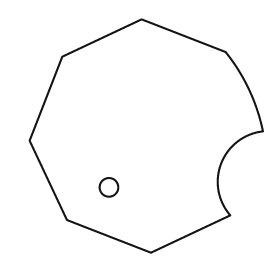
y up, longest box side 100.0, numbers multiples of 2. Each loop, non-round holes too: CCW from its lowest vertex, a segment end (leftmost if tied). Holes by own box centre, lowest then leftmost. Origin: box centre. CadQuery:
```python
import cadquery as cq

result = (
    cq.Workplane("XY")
    .moveTo(2.0, -50.0)
    .lineTo(36.0, -34.0)
    .threePointArc((32.0, -12.0), (50.0, 2.0))
    .threePointArc((44.0, 20.0), (34.0, 36.0))
    .lineTo(-2.0, 50.0)
    .lineTo(-36.0, 34.0)
    .lineTo(-50.0, -2.0)
    .lineTo(-34.0, -36.0)
    .close()
    .moveTo(-16.0, -22.0)
    .circle(4.0)
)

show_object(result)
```